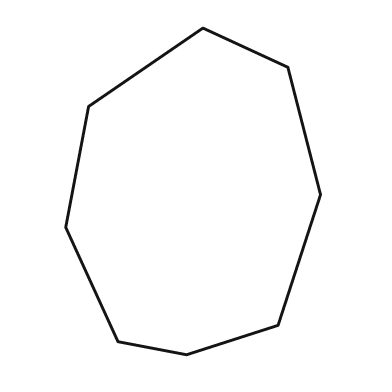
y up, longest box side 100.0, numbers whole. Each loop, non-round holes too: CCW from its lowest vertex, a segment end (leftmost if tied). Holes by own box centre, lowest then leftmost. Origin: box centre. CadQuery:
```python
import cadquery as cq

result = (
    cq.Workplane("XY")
    .moveTo(-2.0, -50.0)
    .lineTo(26.0, -41.0)
    .lineTo(39.0, -1.0)
    .lineTo(29.0, 38.0)
    .lineTo(3.0, 50.0)
    .lineTo(-32.0, 26.0)
    .lineTo(-39.0, -11.0)
    .lineTo(-23.0, -46.0)
    .close()
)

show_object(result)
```